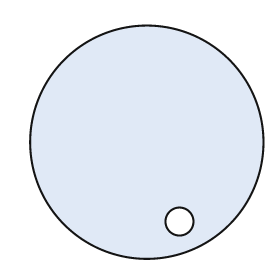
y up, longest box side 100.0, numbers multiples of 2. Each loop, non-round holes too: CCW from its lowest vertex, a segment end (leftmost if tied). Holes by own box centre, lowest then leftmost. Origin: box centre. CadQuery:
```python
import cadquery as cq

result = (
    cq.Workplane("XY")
    .moveTo(0.0, 0.0)
    .circle(50.0)
    .moveTo(14.0, -34.0)
    .circle(6.0)
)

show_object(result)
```